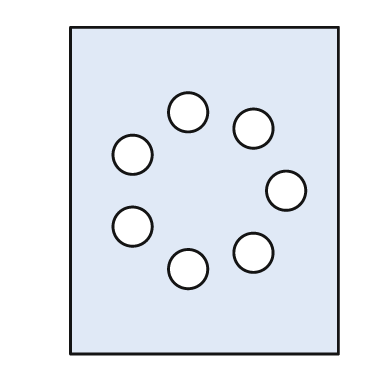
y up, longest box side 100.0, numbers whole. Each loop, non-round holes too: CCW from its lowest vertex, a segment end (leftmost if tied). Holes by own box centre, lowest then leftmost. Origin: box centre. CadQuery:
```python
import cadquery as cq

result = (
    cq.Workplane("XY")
    .moveTo(-41.0, -50.0)
    .lineTo(41.0, -50.0)
    .lineTo(41.0, 50.0)
    .lineTo(-41.0, 50.0)
    .close()
    .moveTo(-5.0, -24.0)
    .circle(6.0)
    .moveTo(15.0, -19.0)
    .circle(6.0)
    .moveTo(-22.0, -11.0)
    .circle(6.0)
    .moveTo(25.0, 0.0)
    .circle(6.0)
    .moveTo(-22.0, 11.0)
    .circle(6.0)
    .moveTo(15.0, 19.0)
    .circle(6.0)
    .moveTo(-5.0, 24.0)
    .circle(6.0)
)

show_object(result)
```